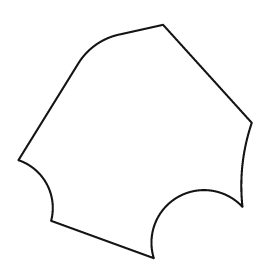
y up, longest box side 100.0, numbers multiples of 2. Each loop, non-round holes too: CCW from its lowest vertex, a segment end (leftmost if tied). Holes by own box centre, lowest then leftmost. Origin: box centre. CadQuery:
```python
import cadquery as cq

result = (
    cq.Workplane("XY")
    .moveTo(8.0, -50.0)
    .threePointArc((18.0, -24.0), (46.0, -28.0))
    .threePointArc((46.0, -10.0), (50.0, 8.0))
    .lineTo(12.0, 50.0)
    .lineTo(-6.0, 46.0)
    .threePointArc((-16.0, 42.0), (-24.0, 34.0))
    .lineTo(-50.0, -8.0)
    .threePointArc((-38.0, -18.0), (-36.0, -34.0))
    .close()
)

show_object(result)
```